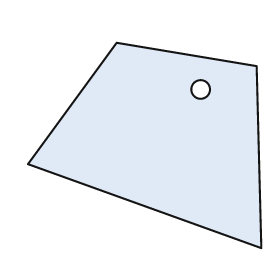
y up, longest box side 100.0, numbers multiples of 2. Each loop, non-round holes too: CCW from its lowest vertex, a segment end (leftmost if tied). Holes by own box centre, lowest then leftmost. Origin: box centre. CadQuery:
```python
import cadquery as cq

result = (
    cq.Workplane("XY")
    .moveTo(50.0, -44.0)
    .lineTo(48.0, 34.0)
    .lineTo(-12.0, 44.0)
    .lineTo(-50.0, -8.0)
    .close()
    .moveTo(24.0, 24.0)
    .circle(4.0)
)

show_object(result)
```